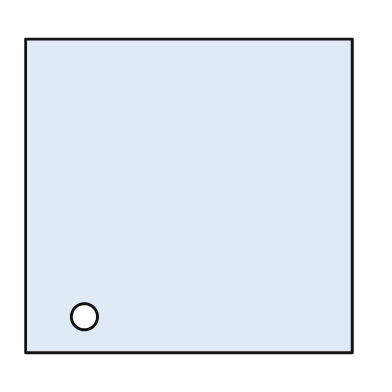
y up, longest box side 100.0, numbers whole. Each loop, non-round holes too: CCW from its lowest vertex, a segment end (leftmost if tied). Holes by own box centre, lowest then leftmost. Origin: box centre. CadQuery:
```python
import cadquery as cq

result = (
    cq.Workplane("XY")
    .moveTo(-50.0, -48.0)
    .lineTo(50.0, -48.0)
    .lineTo(50.0, 48.0)
    .lineTo(-50.0, 48.0)
    .close()
    .moveTo(-32.0, -37.0)
    .circle(4.0)
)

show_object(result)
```